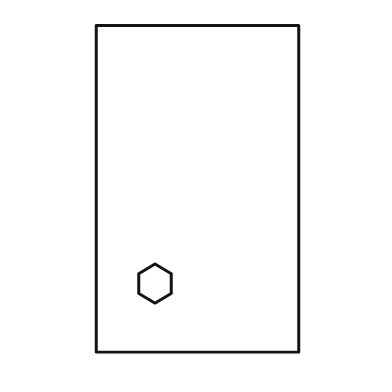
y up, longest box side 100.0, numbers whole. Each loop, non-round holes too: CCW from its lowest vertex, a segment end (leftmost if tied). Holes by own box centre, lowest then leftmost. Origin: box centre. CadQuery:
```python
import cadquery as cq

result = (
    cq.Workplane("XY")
    .moveTo(-31.0, -50.0)
    .lineTo(31.0, -50.0)
    .lineTo(31.0, 50.0)
    .lineTo(-31.0, 50.0)
    .close()
    .moveTo(-13.0, -35.0)
    .lineTo(-8.0, -32.0)
    .lineTo(-8.0, -26.0)
    .lineTo(-13.0, -23.0)
    .lineTo(-18.0, -26.0)
    .lineTo(-18.0, -32.0)
    .close()
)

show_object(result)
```